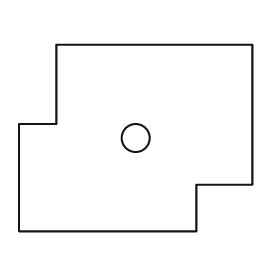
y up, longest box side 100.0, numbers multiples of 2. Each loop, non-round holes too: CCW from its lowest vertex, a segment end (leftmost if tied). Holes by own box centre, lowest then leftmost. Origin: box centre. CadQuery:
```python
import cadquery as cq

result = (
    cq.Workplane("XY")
    .moveTo(-50.0, -40.0)
    .lineTo(26.0, -40.0)
    .lineTo(26.0, -20.0)
    .lineTo(50.0, -20.0)
    .lineTo(50.0, 40.0)
    .lineTo(-34.0, 40.0)
    .lineTo(-34.0, 6.0)
    .lineTo(-50.0, 6.0)
    .close()
    .moveTo(0.0, 0.0)
    .circle(6.0)
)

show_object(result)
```